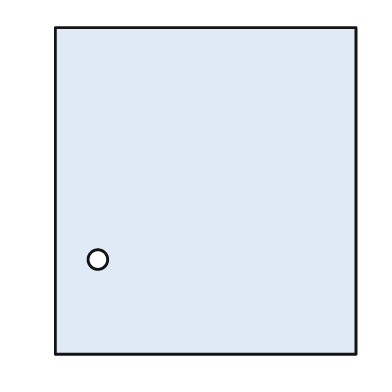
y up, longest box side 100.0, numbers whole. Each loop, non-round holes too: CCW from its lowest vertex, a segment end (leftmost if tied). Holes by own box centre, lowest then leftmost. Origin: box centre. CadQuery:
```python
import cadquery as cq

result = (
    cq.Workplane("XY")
    .moveTo(-46.0, -50.0)
    .lineTo(46.0, -50.0)
    .lineTo(46.0, 50.0)
    .lineTo(-46.0, 50.0)
    .close()
    .moveTo(-33.0, -21.0)
    .circle(3.0)
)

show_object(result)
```